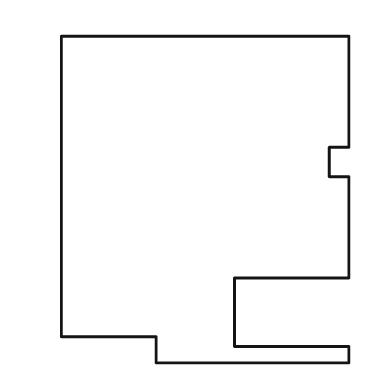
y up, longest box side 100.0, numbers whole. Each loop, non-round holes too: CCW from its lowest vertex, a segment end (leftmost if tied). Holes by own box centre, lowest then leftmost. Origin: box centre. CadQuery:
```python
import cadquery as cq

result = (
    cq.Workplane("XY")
    .moveTo(-15.0, -50.0)
    .lineTo(44.0, -50.0)
    .lineTo(44.0, -45.0)
    .lineTo(9.0, -45.0)
    .lineTo(9.0, -24.0)
    .lineTo(44.0, -24.0)
    .lineTo(44.0, 7.0)
    .lineTo(38.0, 7.0)
    .lineTo(38.0, 16.0)
    .lineTo(44.0, 16.0)
    .lineTo(44.0, 50.0)
    .lineTo(-44.0, 50.0)
    .lineTo(-44.0, -42.0)
    .lineTo(-15.0, -42.0)
    .close()
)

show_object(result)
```